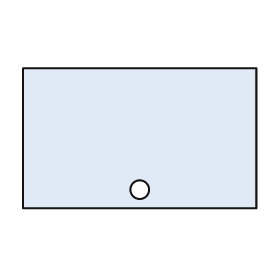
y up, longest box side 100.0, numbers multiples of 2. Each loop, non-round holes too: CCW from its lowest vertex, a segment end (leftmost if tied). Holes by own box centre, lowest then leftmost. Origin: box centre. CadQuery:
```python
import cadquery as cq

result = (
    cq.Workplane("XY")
    .moveTo(-50.0, -30.0)
    .lineTo(50.0, -30.0)
    .lineTo(50.0, 30.0)
    .lineTo(-50.0, 30.0)
    .close()
    .moveTo(0.0, -22.0)
    .circle(4.0)
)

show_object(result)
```